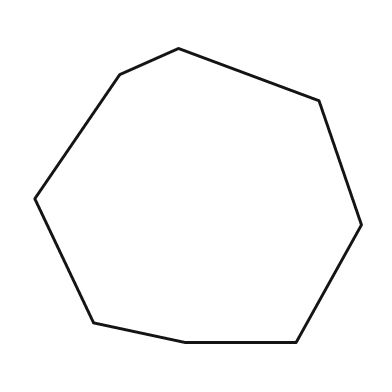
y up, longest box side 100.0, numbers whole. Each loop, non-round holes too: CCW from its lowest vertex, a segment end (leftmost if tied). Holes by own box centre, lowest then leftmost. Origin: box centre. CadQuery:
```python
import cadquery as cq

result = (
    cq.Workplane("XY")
    .moveTo(-4.0, -45.0)
    .lineTo(30.0, -45.0)
    .lineTo(50.0, -9.0)
    .lineTo(37.0, 29.0)
    .lineTo(-6.0, 45.0)
    .lineTo(-24.0, 37.0)
    .lineTo(-50.0, -1.0)
    .lineTo(-32.0, -39.0)
    .close()
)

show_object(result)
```